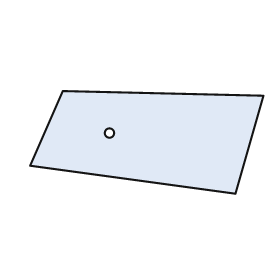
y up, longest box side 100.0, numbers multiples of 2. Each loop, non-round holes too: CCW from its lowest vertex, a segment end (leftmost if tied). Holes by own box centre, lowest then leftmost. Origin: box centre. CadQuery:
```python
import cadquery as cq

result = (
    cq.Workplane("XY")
    .moveTo(38.0, -22.0)
    .lineTo(50.0, 20.0)
    .lineTo(-36.0, 22.0)
    .lineTo(-50.0, -10.0)
    .close()
    .moveTo(-16.0, 4.0)
    .circle(2.0)
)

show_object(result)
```